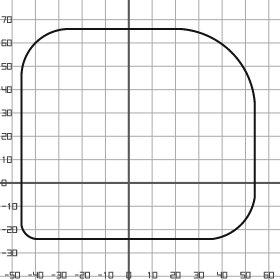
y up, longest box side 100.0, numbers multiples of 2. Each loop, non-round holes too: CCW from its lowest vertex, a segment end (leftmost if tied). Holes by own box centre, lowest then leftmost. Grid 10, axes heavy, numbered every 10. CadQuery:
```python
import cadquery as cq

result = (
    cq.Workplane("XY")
    .moveTo(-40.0, -24.0)
    .lineTo(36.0, -24.0)
    .threePointArc((48.0, -18.0), (54.0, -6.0))
    .lineTo(54.0, 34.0)
    .threePointArc((44.0, 56.0), (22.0, 66.0))
    .lineTo(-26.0, 66.0)
    .threePointArc((-40.0, 60.0), (-46.0, 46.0))
    .lineTo(-46.0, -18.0)
    .threePointArc((-44.0, -22.0), (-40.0, -24.0))
    .close()
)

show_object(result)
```